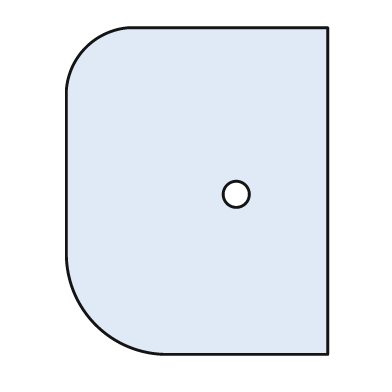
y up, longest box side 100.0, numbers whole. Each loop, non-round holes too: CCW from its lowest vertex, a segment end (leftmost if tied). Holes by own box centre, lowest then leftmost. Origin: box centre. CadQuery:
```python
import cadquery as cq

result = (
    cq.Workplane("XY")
    .moveTo(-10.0, -50.0)
    .lineTo(40.0, -50.0)
    .lineTo(40.0, 50.0)
    .lineTo(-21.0, 50.0)
    .threePointArc((-34.0, 44.0), (-40.0, 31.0))
    .lineTo(-40.0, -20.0)
    .threePointArc((-31.0, -41.0), (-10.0, -50.0))
    .close()
    .moveTo(12.0, -1.0)
    .circle(4.0)
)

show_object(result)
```